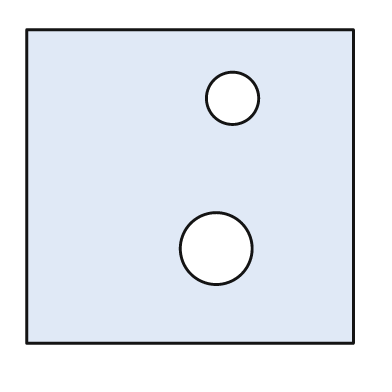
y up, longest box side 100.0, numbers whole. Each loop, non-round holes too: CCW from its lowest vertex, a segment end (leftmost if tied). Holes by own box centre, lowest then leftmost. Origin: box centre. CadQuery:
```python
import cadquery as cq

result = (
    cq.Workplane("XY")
    .moveTo(-50.0, -48.0)
    .lineTo(50.0, -48.0)
    .lineTo(50.0, 48.0)
    .lineTo(-50.0, 48.0)
    .close()
    .moveTo(8.0, -19.0)
    .circle(11.0)
    .moveTo(13.0, 27.0)
    .circle(8.0)
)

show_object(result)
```